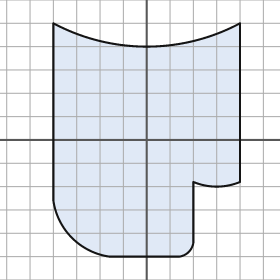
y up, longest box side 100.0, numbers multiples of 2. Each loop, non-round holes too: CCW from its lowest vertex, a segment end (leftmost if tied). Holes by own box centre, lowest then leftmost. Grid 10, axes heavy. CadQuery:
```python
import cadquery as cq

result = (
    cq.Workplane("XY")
    .moveTo(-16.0, -50.0)
    .lineTo(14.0, -50.0)
    .threePointArc((18.0, -48.0), (20.0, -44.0))
    .lineTo(20.0, -18.0)
    .threePointArc((30.0, -20.0), (40.0, -18.0))
    .lineTo(40.0, 50.0)
    .threePointArc((0.0, 40.0), (-40.0, 50.0))
    .lineTo(-40.0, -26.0)
    .threePointArc((-32.0, -42.0), (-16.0, -50.0))
    .close()
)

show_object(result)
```